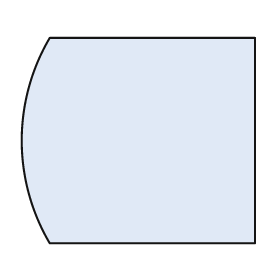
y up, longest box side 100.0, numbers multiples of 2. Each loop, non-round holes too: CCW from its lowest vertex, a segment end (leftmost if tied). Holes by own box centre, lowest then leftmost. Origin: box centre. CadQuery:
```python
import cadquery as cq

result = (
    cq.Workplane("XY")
    .moveTo(-38.0, -44.0)
    .lineTo(50.0, -44.0)
    .lineTo(50.0, 44.0)
    .lineTo(-38.0, 44.0)
    .threePointArc((-50.0, 0.0), (-38.0, -44.0))
    .close()
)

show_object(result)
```